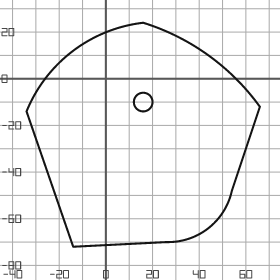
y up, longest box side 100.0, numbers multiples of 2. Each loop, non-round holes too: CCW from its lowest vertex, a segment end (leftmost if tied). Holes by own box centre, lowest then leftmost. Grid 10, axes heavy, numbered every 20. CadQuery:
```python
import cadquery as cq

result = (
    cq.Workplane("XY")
    .moveTo(-14.0, -72.0)
    .lineTo(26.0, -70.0)
    .threePointArc((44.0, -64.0), (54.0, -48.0))
    .lineTo(66.0, -12.0)
    .threePointArc((44.0, 10.0), (16.0, 24.0))
    .threePointArc((-14.0, 12.0), (-34.0, -14.0))
    .close()
    .moveTo(16.0, -10.0)
    .circle(4.0)
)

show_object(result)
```